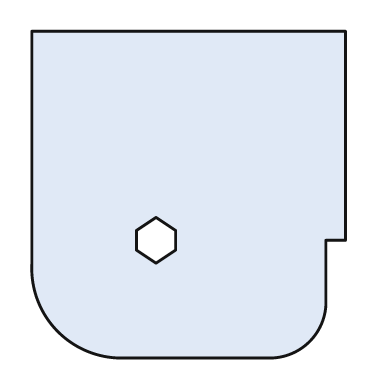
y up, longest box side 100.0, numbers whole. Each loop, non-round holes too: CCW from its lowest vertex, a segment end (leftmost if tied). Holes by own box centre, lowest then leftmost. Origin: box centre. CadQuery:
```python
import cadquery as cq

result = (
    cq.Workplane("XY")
    .moveTo(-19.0, -50.0)
    .lineTo(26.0, -50.0)
    .threePointArc((37.0, -45.0), (42.0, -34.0))
    .lineTo(42.0, -14.0)
    .lineTo(48.0, -14.0)
    .lineTo(48.0, 50.0)
    .lineTo(-48.0, 50.0)
    .lineTo(-48.0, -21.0)
    .threePointArc((-40.0, -42.0), (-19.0, -50.0))
    .close()
    .moveTo(-10.0, -21.0)
    .lineTo(-4.0, -17.0)
    .lineTo(-4.0, -11.0)
    .lineTo(-10.0, -7.0)
    .lineTo(-16.0, -11.0)
    .lineTo(-16.0, -17.0)
    .close()
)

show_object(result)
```